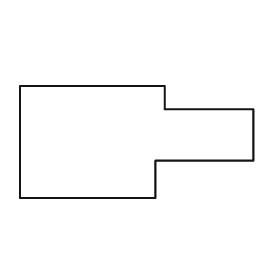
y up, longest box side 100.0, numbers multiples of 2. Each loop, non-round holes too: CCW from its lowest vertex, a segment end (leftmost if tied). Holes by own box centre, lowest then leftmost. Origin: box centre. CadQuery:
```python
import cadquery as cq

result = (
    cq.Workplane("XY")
    .moveTo(-50.0, -24.0)
    .lineTo(8.0, -24.0)
    .lineTo(8.0, -8.0)
    .lineTo(50.0, -8.0)
    .lineTo(50.0, 14.0)
    .lineTo(12.0, 14.0)
    .lineTo(12.0, 24.0)
    .lineTo(-50.0, 24.0)
    .close()
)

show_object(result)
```